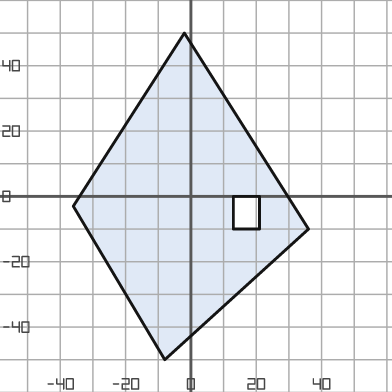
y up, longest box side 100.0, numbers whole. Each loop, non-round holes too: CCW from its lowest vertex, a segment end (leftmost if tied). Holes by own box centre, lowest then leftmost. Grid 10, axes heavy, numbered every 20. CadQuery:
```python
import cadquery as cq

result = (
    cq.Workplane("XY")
    .moveTo(-8.0, -50.0)
    .lineTo(36.0, -10.0)
    .lineTo(-2.0, 50.0)
    .lineTo(-36.0, -3.0)
    .close()
    .moveTo(13.0, -10.0)
    .lineTo(21.0, -10.0)
    .lineTo(21.0, 0.0)
    .lineTo(13.0, 0.0)
    .close()
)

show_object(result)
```